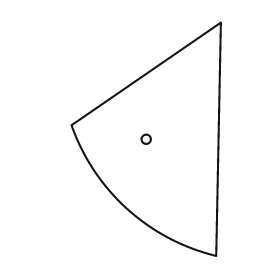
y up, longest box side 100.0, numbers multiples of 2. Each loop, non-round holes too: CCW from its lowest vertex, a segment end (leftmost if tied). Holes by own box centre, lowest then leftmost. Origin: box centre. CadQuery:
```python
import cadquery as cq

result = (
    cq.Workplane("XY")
    .moveTo(30.0, -50.0)
    .lineTo(32.0, 50.0)
    .lineTo(-32.0, 6.0)
    .threePointArc((-8.0, -30.0), (30.0, -50.0))
    .close()
    .moveTo(0.0, 0.0)
    .circle(2.0)
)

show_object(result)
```